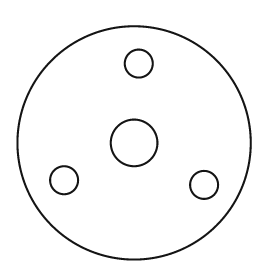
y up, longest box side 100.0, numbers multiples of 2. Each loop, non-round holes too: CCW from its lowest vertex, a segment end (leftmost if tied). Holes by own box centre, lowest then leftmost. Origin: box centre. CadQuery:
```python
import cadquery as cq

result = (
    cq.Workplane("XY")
    .moveTo(0.0, 0.0)
    .circle(50.0)
    .moveTo(30.0, -18.0)
    .circle(6.0)
    .moveTo(-30.0, -16.0)
    .circle(6.0)
    .moveTo(0.0, 0.0)
    .circle(10.0)
    .moveTo(2.0, 34.0)
    .circle(6.0)
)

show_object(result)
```